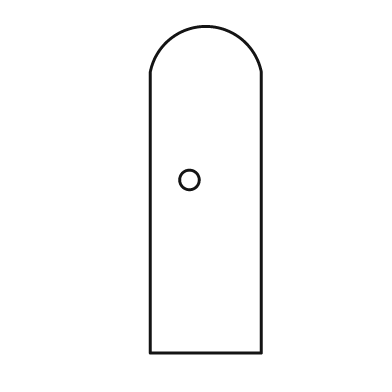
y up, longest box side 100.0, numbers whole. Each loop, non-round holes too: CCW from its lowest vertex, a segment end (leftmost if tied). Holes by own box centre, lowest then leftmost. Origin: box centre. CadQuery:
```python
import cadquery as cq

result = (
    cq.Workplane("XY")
    .moveTo(-17.0, -50.0)
    .lineTo(17.0, -50.0)
    .lineTo(17.0, 36.0)
    .threePointArc((0.0, 50.0), (-17.0, 36.0))
    .close()
    .moveTo(-5.0, 3.0)
    .circle(3.0)
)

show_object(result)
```